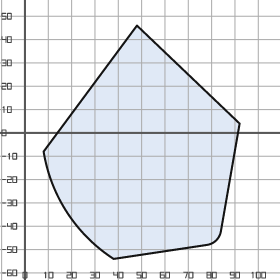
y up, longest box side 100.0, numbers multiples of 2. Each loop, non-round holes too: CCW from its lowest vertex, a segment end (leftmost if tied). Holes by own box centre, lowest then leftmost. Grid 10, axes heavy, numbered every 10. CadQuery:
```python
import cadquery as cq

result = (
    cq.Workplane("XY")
    .moveTo(38.0, -54.0)
    .lineTo(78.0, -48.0)
    .threePointArc((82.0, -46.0), (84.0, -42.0))
    .lineTo(92.0, 4.0)
    .lineTo(48.0, 46.0)
    .lineTo(8.0, -8.0)
    .threePointArc((18.0, -34.0), (38.0, -54.0))
    .close()
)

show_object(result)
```